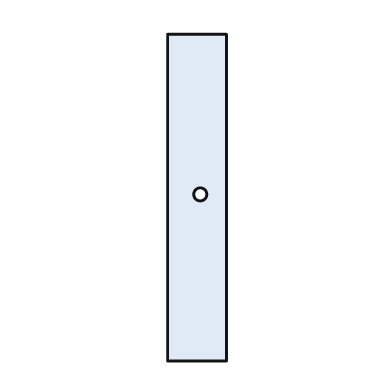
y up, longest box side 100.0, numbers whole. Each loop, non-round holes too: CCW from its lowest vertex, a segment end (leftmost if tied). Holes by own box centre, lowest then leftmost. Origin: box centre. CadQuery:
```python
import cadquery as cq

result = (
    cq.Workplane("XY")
    .moveTo(-9.0, -50.0)
    .lineTo(9.0, -50.0)
    .lineTo(9.0, 50.0)
    .lineTo(-9.0, 50.0)
    .close()
    .moveTo(1.0, 1.0)
    .circle(2.0)
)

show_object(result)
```